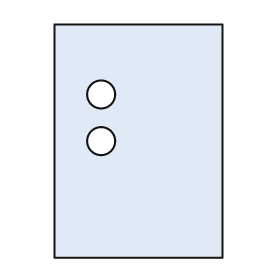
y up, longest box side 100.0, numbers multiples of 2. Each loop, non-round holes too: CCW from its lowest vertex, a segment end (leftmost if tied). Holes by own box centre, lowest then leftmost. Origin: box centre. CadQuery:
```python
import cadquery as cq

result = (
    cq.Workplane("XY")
    .moveTo(-36.0, -50.0)
    .lineTo(36.0, -50.0)
    .lineTo(36.0, 50.0)
    .lineTo(-36.0, 50.0)
    .close()
    .moveTo(-16.0, 0.0)
    .circle(6.0)
    .moveTo(-16.0, 20.0)
    .circle(6.0)
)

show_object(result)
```